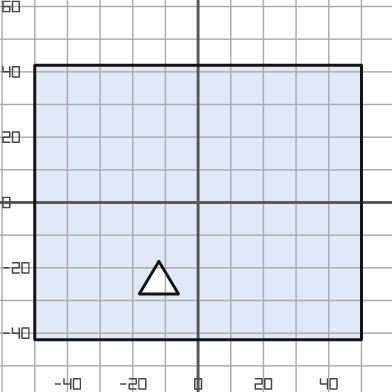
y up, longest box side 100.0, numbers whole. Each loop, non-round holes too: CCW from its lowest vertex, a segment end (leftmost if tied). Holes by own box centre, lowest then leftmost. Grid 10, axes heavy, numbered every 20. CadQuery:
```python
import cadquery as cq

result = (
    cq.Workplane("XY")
    .moveTo(-50.0, -42.0)
    .lineTo(50.0, -42.0)
    .lineTo(50.0, 42.0)
    .lineTo(-50.0, 42.0)
    .close()
    .moveTo(-18.0, -28.0)
    .lineTo(-6.0, -28.0)
    .lineTo(-12.0, -18.0)
    .close()
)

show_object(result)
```